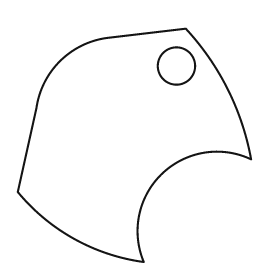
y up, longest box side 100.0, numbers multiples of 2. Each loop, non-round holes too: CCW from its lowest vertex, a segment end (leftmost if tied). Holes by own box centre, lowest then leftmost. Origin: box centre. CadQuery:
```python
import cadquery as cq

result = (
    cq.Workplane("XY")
    .moveTo(4.0, -50.0)
    .threePointArc((12.0, -12.0), (50.0, -6.0))
    .threePointArc((40.0, 24.0), (22.0, 50.0))
    .lineTo(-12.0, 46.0)
    .threePointArc((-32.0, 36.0), (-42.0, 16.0))
    .lineTo(-50.0, -20.0)
    .threePointArc((-26.0, -40.0), (4.0, -50.0))
    .close()
    .moveTo(18.0, 34.0)
    .circle(8.0)
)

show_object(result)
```